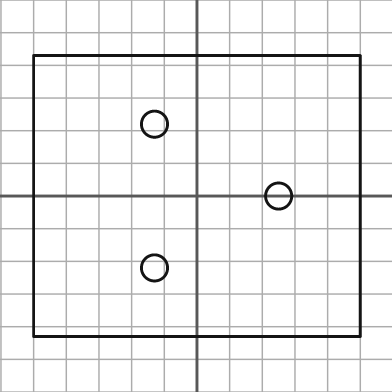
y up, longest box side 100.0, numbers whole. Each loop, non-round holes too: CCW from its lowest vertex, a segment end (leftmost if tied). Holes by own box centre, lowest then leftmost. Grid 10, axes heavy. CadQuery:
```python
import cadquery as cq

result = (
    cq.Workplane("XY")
    .moveTo(-50.0, -43.0)
    .lineTo(50.0, -43.0)
    .lineTo(50.0, 43.0)
    .lineTo(-50.0, 43.0)
    .close()
    .moveTo(-13.0, -22.0)
    .circle(4.0)
    .moveTo(25.0, 0.0)
    .circle(4.0)
    .moveTo(-13.0, 22.0)
    .circle(4.0)
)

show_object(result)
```